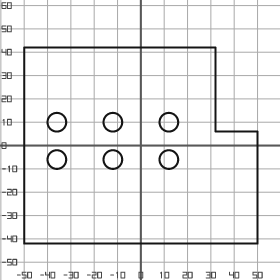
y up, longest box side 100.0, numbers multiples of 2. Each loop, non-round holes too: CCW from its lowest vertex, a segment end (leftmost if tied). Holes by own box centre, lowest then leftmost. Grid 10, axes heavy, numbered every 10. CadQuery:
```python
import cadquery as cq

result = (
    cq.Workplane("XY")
    .moveTo(-50.0, -42.0)
    .lineTo(50.0, -42.0)
    .lineTo(50.0, 6.0)
    .lineTo(32.0, 6.0)
    .lineTo(32.0, 42.0)
    .lineTo(-50.0, 42.0)
    .close()
    .moveTo(-36.0, -6.0)
    .circle(4.0)
    .moveTo(-12.0, -6.0)
    .circle(4.0)
    .moveTo(12.0, -6.0)
    .circle(4.0)
    .moveTo(-36.0, 10.0)
    .circle(4.0)
    .moveTo(-12.0, 10.0)
    .circle(4.0)
    .moveTo(12.0, 10.0)
    .circle(4.0)
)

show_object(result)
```